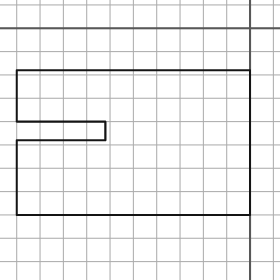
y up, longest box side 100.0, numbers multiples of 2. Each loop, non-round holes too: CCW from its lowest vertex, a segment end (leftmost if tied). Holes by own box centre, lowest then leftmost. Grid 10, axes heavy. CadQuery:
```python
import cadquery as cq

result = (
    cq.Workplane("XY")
    .moveTo(-100.0, -80.0)
    .lineTo(0.0, -80.0)
    .lineTo(0.0, -18.0)
    .lineTo(-100.0, -18.0)
    .lineTo(-100.0, -40.0)
    .lineTo(-62.0, -40.0)
    .lineTo(-62.0, -48.0)
    .lineTo(-100.0, -48.0)
    .close()
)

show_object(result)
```